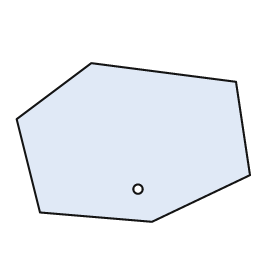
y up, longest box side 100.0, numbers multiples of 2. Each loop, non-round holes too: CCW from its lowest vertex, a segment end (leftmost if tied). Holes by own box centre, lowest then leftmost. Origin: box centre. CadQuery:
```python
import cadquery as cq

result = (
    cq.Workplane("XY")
    .moveTo(8.0, -34.0)
    .lineTo(50.0, -14.0)
    .lineTo(44.0, 26.0)
    .lineTo(-18.0, 34.0)
    .lineTo(-50.0, 10.0)
    .lineTo(-40.0, -30.0)
    .close()
    .moveTo(2.0, -20.0)
    .circle(2.0)
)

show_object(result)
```